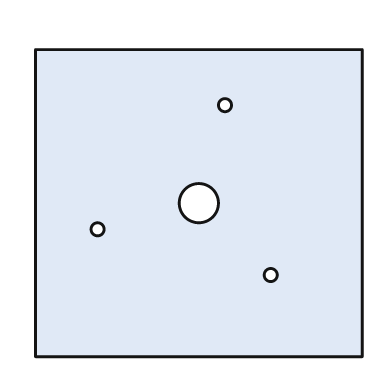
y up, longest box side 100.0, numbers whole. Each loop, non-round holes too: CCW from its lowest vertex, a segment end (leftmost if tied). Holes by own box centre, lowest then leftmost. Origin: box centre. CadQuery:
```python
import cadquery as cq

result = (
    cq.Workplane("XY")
    .moveTo(-50.0, -47.0)
    .lineTo(50.0, -47.0)
    .lineTo(50.0, 47.0)
    .lineTo(-50.0, 47.0)
    .close()
    .moveTo(22.0, -22.0)
    .circle(2.0)
    .moveTo(-31.0, -8.0)
    .circle(2.0)
    .moveTo(0.0, 0.0)
    .circle(6.0)
    .moveTo(8.0, 30.0)
    .circle(2.0)
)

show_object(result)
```